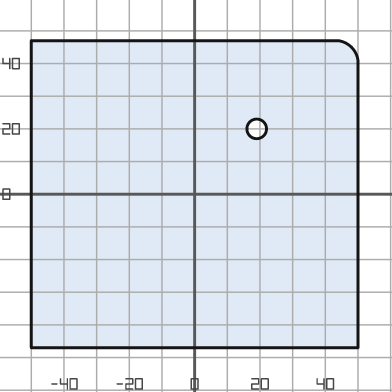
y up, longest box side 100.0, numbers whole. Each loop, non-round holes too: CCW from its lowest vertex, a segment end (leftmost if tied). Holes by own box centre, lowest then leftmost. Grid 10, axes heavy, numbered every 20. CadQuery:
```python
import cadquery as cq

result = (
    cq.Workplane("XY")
    .moveTo(-50.0, -47.0)
    .lineTo(50.0, -47.0)
    .lineTo(50.0, 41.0)
    .threePointArc((48.0, 45.0), (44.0, 47.0))
    .lineTo(-50.0, 47.0)
    .close()
    .moveTo(19.0, 20.0)
    .circle(3.0)
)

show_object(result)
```